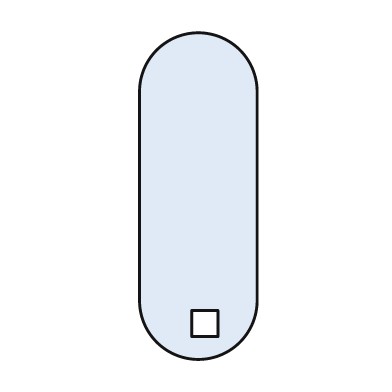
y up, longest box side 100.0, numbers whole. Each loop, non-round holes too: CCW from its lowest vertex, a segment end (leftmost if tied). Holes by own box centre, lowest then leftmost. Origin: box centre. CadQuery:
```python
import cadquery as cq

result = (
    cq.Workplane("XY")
    .moveTo(-18.0, -32.0)
    .threePointArc((0.0, -50.0), (18.0, -32.0))
    .lineTo(18.0, 32.0)
    .threePointArc((0.0, 50.0), (-18.0, 32.0))
    .close()
    .moveTo(-2.0, -43.0)
    .lineTo(6.0, -43.0)
    .lineTo(6.0, -35.0)
    .lineTo(-2.0, -35.0)
    .close()
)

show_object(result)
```